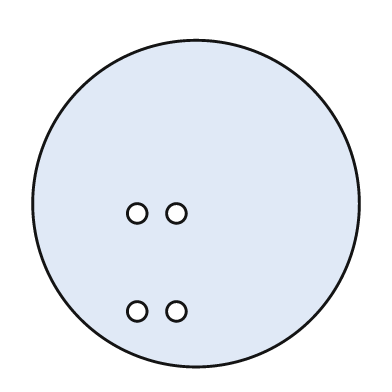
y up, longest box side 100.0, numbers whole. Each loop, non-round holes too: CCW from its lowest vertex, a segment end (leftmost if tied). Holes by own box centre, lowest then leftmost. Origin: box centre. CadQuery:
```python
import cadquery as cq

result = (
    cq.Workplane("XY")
    .moveTo(0.0, 0.0)
    .circle(50.0)
    .moveTo(-18.0, -33.0)
    .circle(3.0)
    .moveTo(-6.0, -33.0)
    .circle(3.0)
    .moveTo(-18.0, -3.0)
    .circle(3.0)
    .moveTo(-6.0, -3.0)
    .circle(3.0)
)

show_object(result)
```